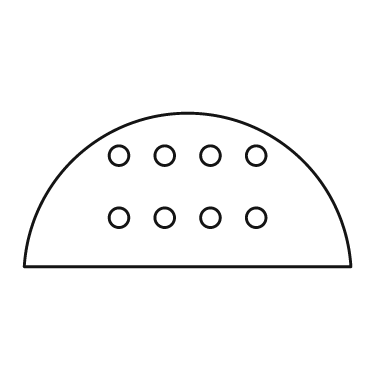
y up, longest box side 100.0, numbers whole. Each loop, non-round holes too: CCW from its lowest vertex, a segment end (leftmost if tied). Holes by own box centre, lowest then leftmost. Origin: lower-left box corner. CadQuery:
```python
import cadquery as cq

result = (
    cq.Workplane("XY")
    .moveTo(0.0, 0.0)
    .lineTo(100.0, 0.0)
    .threePointArc((50.0, 47.0), (0.0, 0.0))
    .close()
    .moveTo(29.0, 15.0)
    .circle(3.0)
    .moveTo(43.0, 15.0)
    .circle(3.0)
    .moveTo(57.0, 15.0)
    .circle(3.0)
    .moveTo(71.0, 15.0)
    .circle(3.0)
    .moveTo(29.0, 34.0)
    .circle(3.0)
    .moveTo(43.0, 34.0)
    .circle(3.0)
    .moveTo(57.0, 34.0)
    .circle(3.0)
    .moveTo(71.0, 34.0)
    .circle(3.0)
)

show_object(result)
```